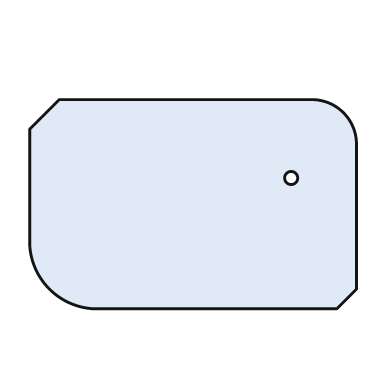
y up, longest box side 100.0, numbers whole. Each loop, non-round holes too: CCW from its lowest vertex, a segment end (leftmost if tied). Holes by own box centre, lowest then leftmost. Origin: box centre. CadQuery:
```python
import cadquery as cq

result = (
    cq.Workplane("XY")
    .moveTo(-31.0, -32.0)
    .lineTo(44.0, -32.0)
    .lineTo(50.0, -26.0)
    .lineTo(50.0, 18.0)
    .threePointArc((46.0, 28.0), (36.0, 32.0))
    .lineTo(-41.0, 32.0)
    .lineTo(-50.0, 23.0)
    .lineTo(-50.0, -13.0)
    .threePointArc((-44.0, -26.0), (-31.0, -32.0))
    .close()
    .moveTo(30.0, 8.0)
    .circle(2.0)
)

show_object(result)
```